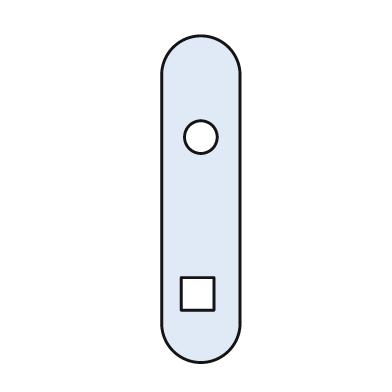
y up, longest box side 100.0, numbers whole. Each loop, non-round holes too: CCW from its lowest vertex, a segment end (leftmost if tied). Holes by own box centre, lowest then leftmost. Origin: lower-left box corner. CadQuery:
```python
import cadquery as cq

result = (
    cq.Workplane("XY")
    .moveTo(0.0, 12.0)
    .threePointArc((12.0, 0.0), (24.0, 12.0))
    .lineTo(24.0, 88.0)
    .threePointArc((12.0, 100.0), (0.0, 88.0))
    .close()
    .moveTo(6.0, 16.0)
    .lineTo(16.0, 16.0)
    .lineTo(16.0, 26.0)
    .lineTo(6.0, 26.0)
    .close()
    .moveTo(12.0, 69.0)
    .circle(5.0)
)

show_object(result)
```